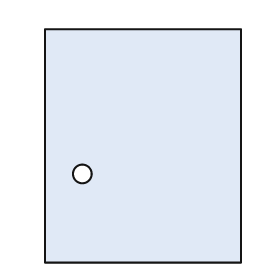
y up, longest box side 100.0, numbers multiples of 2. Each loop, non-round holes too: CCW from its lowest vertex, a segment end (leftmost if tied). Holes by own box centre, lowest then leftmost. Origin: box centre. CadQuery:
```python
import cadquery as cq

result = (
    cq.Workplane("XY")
    .moveTo(-42.0, -50.0)
    .lineTo(42.0, -50.0)
    .lineTo(42.0, 50.0)
    .lineTo(-42.0, 50.0)
    .close()
    .moveTo(-26.0, -12.0)
    .circle(4.0)
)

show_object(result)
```